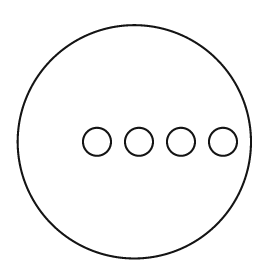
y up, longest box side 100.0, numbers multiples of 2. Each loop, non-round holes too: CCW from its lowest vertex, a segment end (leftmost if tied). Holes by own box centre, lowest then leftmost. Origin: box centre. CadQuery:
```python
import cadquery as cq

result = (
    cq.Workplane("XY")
    .moveTo(0.0, 0.0)
    .circle(50.0)
    .moveTo(-16.0, 0.0)
    .circle(6.0)
    .moveTo(2.0, 0.0)
    .circle(6.0)
    .moveTo(20.0, 0.0)
    .circle(6.0)
    .moveTo(38.0, 0.0)
    .circle(6.0)
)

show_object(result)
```